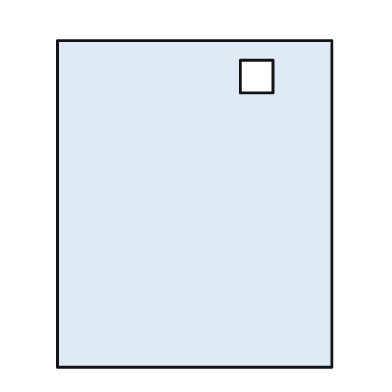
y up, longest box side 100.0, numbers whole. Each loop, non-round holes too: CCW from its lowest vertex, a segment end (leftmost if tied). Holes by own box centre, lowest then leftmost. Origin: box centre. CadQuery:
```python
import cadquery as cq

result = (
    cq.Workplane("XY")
    .moveTo(-42.0, -50.0)
    .lineTo(42.0, -50.0)
    .lineTo(42.0, 50.0)
    .lineTo(-42.0, 50.0)
    .close()
    .moveTo(14.0, 34.0)
    .lineTo(24.0, 34.0)
    .lineTo(24.0, 44.0)
    .lineTo(14.0, 44.0)
    .close()
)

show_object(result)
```